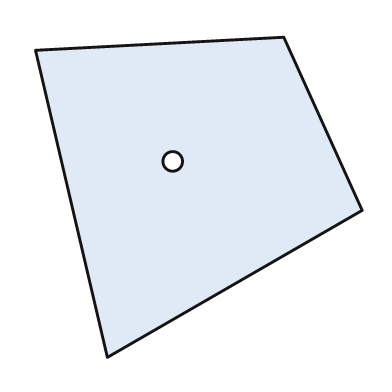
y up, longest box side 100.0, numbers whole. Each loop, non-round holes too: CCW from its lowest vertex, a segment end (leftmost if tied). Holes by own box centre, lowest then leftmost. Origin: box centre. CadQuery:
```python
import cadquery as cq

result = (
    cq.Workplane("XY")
    .moveTo(-28.0, -49.0)
    .lineTo(50.0, -4.0)
    .lineTo(26.0, 49.0)
    .lineTo(-50.0, 45.0)
    .close()
    .moveTo(-8.0, 11.0)
    .circle(3.0)
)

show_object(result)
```